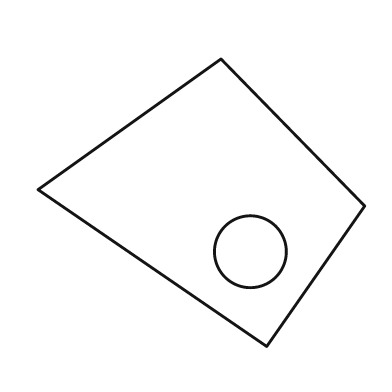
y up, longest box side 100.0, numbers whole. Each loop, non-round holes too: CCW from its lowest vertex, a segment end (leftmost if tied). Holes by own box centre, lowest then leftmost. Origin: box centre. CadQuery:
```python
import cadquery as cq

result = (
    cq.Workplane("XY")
    .moveTo(20.0, -44.0)
    .lineTo(50.0, -1.0)
    .lineTo(6.0, 44.0)
    .lineTo(-50.0, 4.0)
    .close()
    .moveTo(15.0, -15.0)
    .circle(11.0)
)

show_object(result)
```